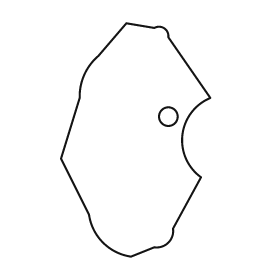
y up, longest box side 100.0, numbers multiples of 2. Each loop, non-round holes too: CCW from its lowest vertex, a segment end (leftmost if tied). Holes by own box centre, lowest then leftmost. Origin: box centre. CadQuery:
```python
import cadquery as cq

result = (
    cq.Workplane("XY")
    .moveTo(-2.0, -50.0)
    .lineTo(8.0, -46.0)
    .threePointArc((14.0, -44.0), (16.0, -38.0))
    .lineTo(28.0, -16.0)
    .threePointArc((20.0, 2.0), (32.0, 18.0))
    .lineTo(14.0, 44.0)
    .threePointArc((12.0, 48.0), (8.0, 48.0))
    .lineTo(-4.0, 50.0)
    .lineTo(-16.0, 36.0)
    .threePointArc((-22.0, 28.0), (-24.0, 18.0))
    .lineTo(-32.0, -8.0)
    .lineTo(-20.0, -32.0)
    .threePointArc((-14.0, -44.0), (-2.0, -50.0))
    .close()
    .moveTo(14.0, 10.0)
    .circle(4.0)
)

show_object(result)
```